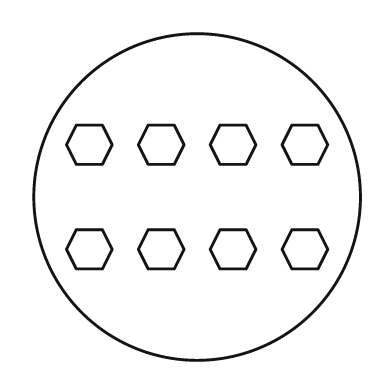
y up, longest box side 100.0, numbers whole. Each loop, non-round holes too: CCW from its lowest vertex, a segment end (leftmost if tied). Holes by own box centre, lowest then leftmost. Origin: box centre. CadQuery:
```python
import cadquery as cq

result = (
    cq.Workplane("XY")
    .moveTo(0.0, 0.0)
    .circle(50.0)
    .moveTo(-37.0, -22.0)
    .lineTo(-29.0, -22.0)
    .lineTo(-26.0, -16.0)
    .lineTo(-29.0, -10.0)
    .lineTo(-37.0, -10.0)
    .lineTo(-40.0, -16.0)
    .close()
    .moveTo(-15.0, -22.0)
    .lineTo(-7.0, -22.0)
    .lineTo(-4.0, -16.0)
    .lineTo(-7.0, -10.0)
    .lineTo(-15.0, -10.0)
    .lineTo(-18.0, -16.0)
    .close()
    .moveTo(7.0, -22.0)
    .lineTo(15.0, -22.0)
    .lineTo(18.0, -16.0)
    .lineTo(15.0, -10.0)
    .lineTo(7.0, -10.0)
    .lineTo(4.0, -16.0)
    .close()
    .moveTo(29.0, -22.0)
    .lineTo(37.0, -22.0)
    .lineTo(40.0, -16.0)
    .lineTo(37.0, -10.0)
    .lineTo(29.0, -10.0)
    .lineTo(26.0, -16.0)
    .close()
    .moveTo(-37.0, 10.0)
    .lineTo(-29.0, 10.0)
    .lineTo(-26.0, 16.0)
    .lineTo(-29.0, 22.0)
    .lineTo(-37.0, 22.0)
    .lineTo(-40.0, 16.0)
    .close()
    .moveTo(-15.0, 10.0)
    .lineTo(-7.0, 10.0)
    .lineTo(-4.0, 16.0)
    .lineTo(-7.0, 22.0)
    .lineTo(-15.0, 22.0)
    .lineTo(-18.0, 16.0)
    .close()
    .moveTo(7.0, 10.0)
    .lineTo(15.0, 10.0)
    .lineTo(18.0, 16.0)
    .lineTo(15.0, 22.0)
    .lineTo(7.0, 22.0)
    .lineTo(4.0, 16.0)
    .close()
    .moveTo(29.0, 10.0)
    .lineTo(37.0, 10.0)
    .lineTo(40.0, 16.0)
    .lineTo(37.0, 22.0)
    .lineTo(29.0, 22.0)
    .lineTo(26.0, 16.0)
    .close()
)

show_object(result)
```